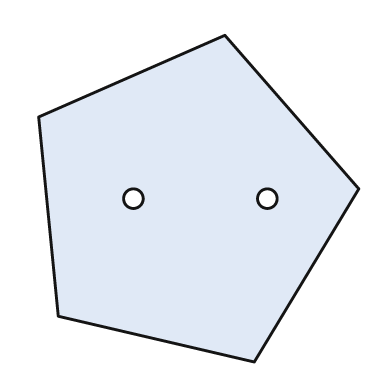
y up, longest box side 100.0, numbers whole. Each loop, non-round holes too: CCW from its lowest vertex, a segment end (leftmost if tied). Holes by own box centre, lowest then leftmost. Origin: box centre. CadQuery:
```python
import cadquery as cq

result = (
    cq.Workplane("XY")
    .moveTo(17.0, -50.0)
    .lineTo(49.0, 3.0)
    .lineTo(8.0, 50.0)
    .lineTo(-49.0, 25.0)
    .lineTo(-43.0, -36.0)
    .close()
    .moveTo(-20.0, 0.0)
    .circle(3.0)
    .moveTo(21.0, 0.0)
    .circle(3.0)
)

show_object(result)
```